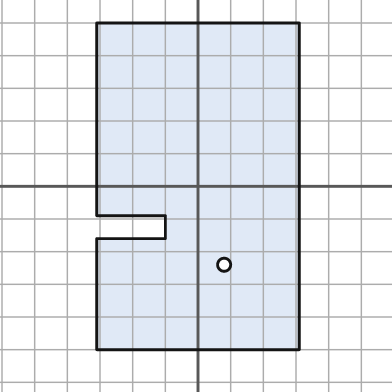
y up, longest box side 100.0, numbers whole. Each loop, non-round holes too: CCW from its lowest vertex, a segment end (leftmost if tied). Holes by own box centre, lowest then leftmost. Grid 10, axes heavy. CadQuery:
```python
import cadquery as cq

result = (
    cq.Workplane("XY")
    .moveTo(-31.0, -50.0)
    .lineTo(31.0, -50.0)
    .lineTo(31.0, 50.0)
    .lineTo(-31.0, 50.0)
    .lineTo(-31.0, -9.0)
    .lineTo(-10.0, -9.0)
    .lineTo(-10.0, -16.0)
    .lineTo(-31.0, -16.0)
    .close()
    .moveTo(8.0, -24.0)
    .circle(2.0)
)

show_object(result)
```